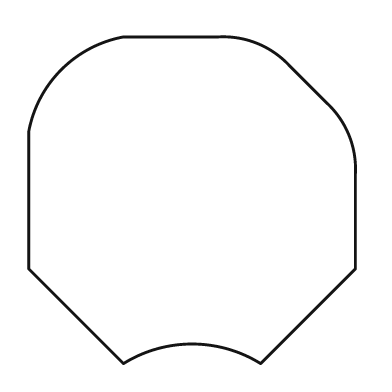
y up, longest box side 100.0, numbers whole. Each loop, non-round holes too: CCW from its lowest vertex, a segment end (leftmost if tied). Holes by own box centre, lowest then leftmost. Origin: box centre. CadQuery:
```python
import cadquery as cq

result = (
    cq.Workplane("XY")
    .moveTo(-21.0, -50.0)
    .threePointArc((0.0, -44.0), (21.0, -50.0))
    .lineTo(50.0, -21.0)
    .lineTo(50.0, 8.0)
    .threePointArc((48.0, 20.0), (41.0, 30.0))
    .lineTo(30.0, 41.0)
    .threePointArc((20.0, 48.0), (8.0, 50.0))
    .lineTo(-21.0, 50.0)
    .threePointArc((-40.0, 40.0), (-50.0, 21.0))
    .lineTo(-50.0, -21.0)
    .close()
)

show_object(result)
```